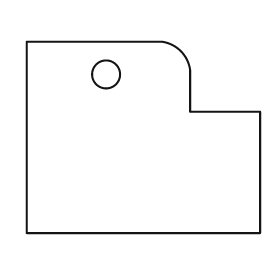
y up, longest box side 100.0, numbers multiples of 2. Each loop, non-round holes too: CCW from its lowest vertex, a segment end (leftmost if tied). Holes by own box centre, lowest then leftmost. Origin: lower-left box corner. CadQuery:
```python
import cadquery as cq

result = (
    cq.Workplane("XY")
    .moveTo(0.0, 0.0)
    .lineTo(100.0, 0.0)
    .lineTo(100.0, 52.0)
    .lineTo(70.0, 52.0)
    .lineTo(70.0, 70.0)
    .threePointArc((66.0, 78.0), (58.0, 82.0))
    .lineTo(0.0, 82.0)
    .close()
    .moveTo(34.0, 68.0)
    .circle(6.0)
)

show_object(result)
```